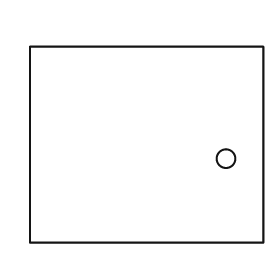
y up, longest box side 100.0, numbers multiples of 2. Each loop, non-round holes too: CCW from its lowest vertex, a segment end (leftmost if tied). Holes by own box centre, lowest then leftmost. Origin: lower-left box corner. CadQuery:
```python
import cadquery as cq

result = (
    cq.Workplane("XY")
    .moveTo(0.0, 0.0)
    .lineTo(100.0, 0.0)
    .lineTo(100.0, 84.0)
    .lineTo(0.0, 84.0)
    .close()
    .moveTo(84.0, 36.0)
    .circle(4.0)
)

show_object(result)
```